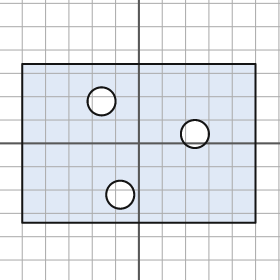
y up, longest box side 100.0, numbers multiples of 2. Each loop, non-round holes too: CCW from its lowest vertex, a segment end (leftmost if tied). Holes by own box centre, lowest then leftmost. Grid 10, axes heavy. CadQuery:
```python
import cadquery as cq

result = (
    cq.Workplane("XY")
    .moveTo(-50.0, -34.0)
    .lineTo(50.0, -34.0)
    .lineTo(50.0, 34.0)
    .lineTo(-50.0, 34.0)
    .close()
    .moveTo(-8.0, -22.0)
    .circle(6.0)
    .moveTo(24.0, 4.0)
    .circle(6.0)
    .moveTo(-16.0, 18.0)
    .circle(6.0)
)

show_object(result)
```